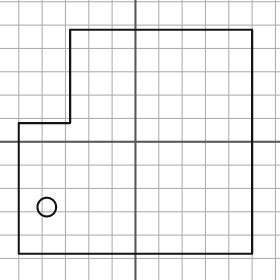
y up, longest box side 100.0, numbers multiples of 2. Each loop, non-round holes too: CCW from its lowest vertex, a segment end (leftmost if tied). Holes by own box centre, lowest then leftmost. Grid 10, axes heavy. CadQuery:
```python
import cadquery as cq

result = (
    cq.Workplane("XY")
    .moveTo(-50.0, -48.0)
    .lineTo(50.0, -48.0)
    .lineTo(50.0, 48.0)
    .lineTo(-28.0, 48.0)
    .lineTo(-28.0, 8.0)
    .lineTo(-50.0, 8.0)
    .close()
    .moveTo(-38.0, -28.0)
    .circle(4.0)
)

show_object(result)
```